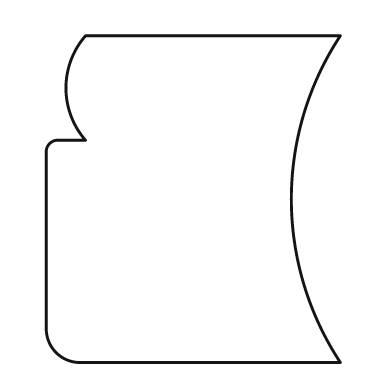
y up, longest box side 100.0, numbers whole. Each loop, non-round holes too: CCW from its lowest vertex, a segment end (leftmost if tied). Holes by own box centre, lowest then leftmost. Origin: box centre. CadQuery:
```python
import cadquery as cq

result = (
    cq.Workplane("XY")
    .moveTo(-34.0, -50.0)
    .lineTo(45.0, -50.0)
    .threePointArc((30.0, 0.0), (45.0, 50.0))
    .lineTo(-33.0, 50.0)
    .threePointArc((-39.0, 34.0), (-33.0, 18.0))
    .lineTo(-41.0, 18.0)
    .threePointArc((-44.0, 17.0), (-45.0, 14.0))
    .lineTo(-45.0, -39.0)
    .threePointArc((-42.0, -47.0), (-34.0, -50.0))
    .close()
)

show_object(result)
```